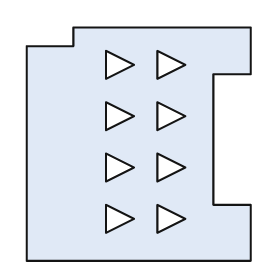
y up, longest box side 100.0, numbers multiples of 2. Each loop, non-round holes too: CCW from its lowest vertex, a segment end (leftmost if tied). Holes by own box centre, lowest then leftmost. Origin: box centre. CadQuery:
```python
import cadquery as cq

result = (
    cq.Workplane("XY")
    .moveTo(-48.0, -50.0)
    .lineTo(48.0, -50.0)
    .lineTo(48.0, -26.0)
    .lineTo(32.0, -26.0)
    .lineTo(32.0, 30.0)
    .lineTo(48.0, 30.0)
    .lineTo(48.0, 50.0)
    .lineTo(-28.0, 50.0)
    .lineTo(-28.0, 42.0)
    .lineTo(-48.0, 42.0)
    .close()
    .moveTo(-14.0, -38.0)
    .lineTo(-2.0, -32.0)
    .lineTo(-14.0, -26.0)
    .close()
    .moveTo(8.0, -38.0)
    .lineTo(20.0, -32.0)
    .lineTo(8.0, -26.0)
    .close()
    .moveTo(-14.0, -16.0)
    .lineTo(-2.0, -10.0)
    .lineTo(-14.0, -4.0)
    .close()
    .moveTo(8.0, -16.0)
    .lineTo(20.0, -10.0)
    .lineTo(8.0, -4.0)
    .close()
    .moveTo(-14.0, 6.0)
    .lineTo(-2.0, 12.0)
    .lineTo(-14.0, 18.0)
    .close()
    .moveTo(8.0, 6.0)
    .lineTo(20.0, 12.0)
    .lineTo(8.0, 18.0)
    .close()
    .moveTo(-14.0, 28.0)
    .lineTo(-2.0, 34.0)
    .lineTo(-14.0, 40.0)
    .close()
    .moveTo(8.0, 28.0)
    .lineTo(20.0, 34.0)
    .lineTo(8.0, 40.0)
    .close()
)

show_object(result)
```